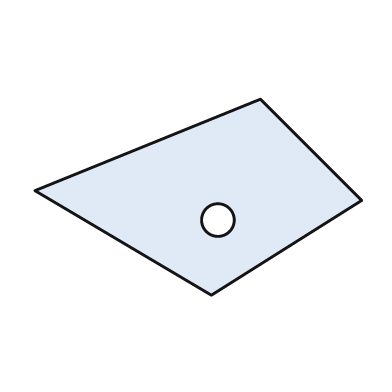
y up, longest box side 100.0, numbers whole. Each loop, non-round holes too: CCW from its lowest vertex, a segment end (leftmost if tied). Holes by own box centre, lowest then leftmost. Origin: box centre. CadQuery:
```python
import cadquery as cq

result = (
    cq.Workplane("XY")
    .moveTo(4.0, -30.0)
    .lineTo(50.0, -1.0)
    .lineTo(19.0, 30.0)
    .lineTo(-50.0, 2.0)
    .close()
    .moveTo(6.0, -7.0)
    .circle(5.0)
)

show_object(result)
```